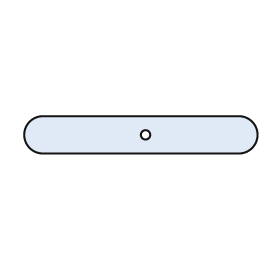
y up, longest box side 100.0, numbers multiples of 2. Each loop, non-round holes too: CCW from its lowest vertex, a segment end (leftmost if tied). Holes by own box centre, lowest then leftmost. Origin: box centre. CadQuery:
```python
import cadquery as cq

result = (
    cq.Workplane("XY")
    .moveTo(-42.0, -8.0)
    .lineTo(42.0, -8.0)
    .threePointArc((50.0, 0.0), (42.0, 8.0))
    .lineTo(-42.0, 8.0)
    .threePointArc((-50.0, 0.0), (-42.0, -8.0))
    .close()
    .moveTo(2.0, 0.0)
    .circle(2.0)
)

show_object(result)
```